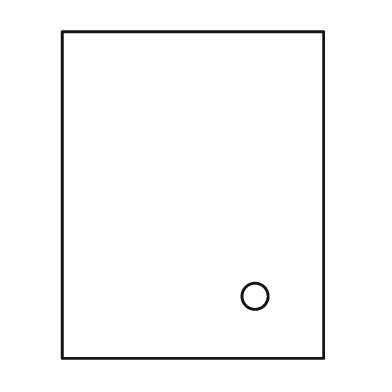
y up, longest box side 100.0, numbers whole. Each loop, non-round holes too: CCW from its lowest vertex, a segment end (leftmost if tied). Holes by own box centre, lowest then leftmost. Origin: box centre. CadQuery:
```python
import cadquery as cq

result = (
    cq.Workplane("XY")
    .moveTo(-40.0, -50.0)
    .lineTo(40.0, -50.0)
    .lineTo(40.0, 50.0)
    .lineTo(-40.0, 50.0)
    .close()
    .moveTo(19.0, -31.0)
    .circle(4.0)
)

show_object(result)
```